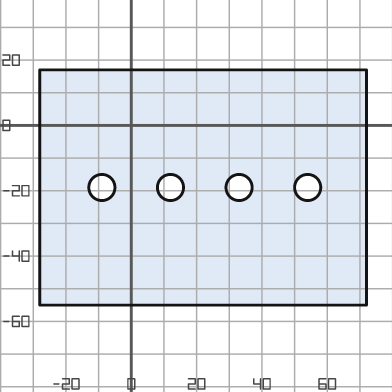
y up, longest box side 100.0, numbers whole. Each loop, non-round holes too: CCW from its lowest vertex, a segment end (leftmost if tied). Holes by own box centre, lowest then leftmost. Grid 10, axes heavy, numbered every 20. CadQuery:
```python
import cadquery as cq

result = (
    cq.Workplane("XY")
    .moveTo(-28.0, -55.0)
    .lineTo(72.0, -55.0)
    .lineTo(72.0, 17.0)
    .lineTo(-28.0, 17.0)
    .close()
    .moveTo(-9.0, -19.0)
    .circle(4.0)
    .moveTo(12.0, -19.0)
    .circle(4.0)
    .moveTo(33.0, -19.0)
    .circle(4.0)
    .moveTo(54.0, -19.0)
    .circle(4.0)
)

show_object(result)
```